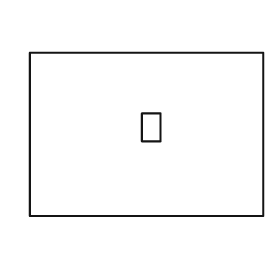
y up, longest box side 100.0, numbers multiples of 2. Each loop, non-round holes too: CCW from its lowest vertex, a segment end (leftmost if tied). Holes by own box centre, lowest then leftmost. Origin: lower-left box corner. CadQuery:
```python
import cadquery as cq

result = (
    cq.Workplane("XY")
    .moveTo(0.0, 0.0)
    .lineTo(100.0, 0.0)
    .lineTo(100.0, 70.0)
    .lineTo(0.0, 70.0)
    .close()
    .moveTo(48.0, 32.0)
    .lineTo(56.0, 32.0)
    .lineTo(56.0, 44.0)
    .lineTo(48.0, 44.0)
    .close()
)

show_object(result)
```